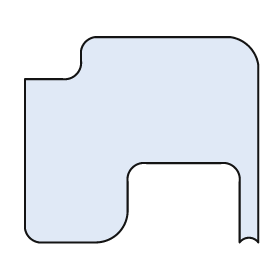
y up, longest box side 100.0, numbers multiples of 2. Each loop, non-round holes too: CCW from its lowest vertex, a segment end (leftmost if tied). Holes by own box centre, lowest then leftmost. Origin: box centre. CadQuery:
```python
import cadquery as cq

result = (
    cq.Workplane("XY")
    .moveTo(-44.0, -44.0)
    .lineTo(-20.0, -44.0)
    .threePointArc((-10.0, -40.0), (-6.0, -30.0))
    .lineTo(-6.0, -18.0)
    .threePointArc((-4.0, -12.0), (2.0, -10.0))
    .lineTo(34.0, -10.0)
    .threePointArc((40.0, -12.0), (42.0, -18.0))
    .lineTo(42.0, -44.0)
    .threePointArc((46.0, -42.0), (50.0, -44.0))
    .lineTo(50.0, 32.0)
    .threePointArc((46.0, 40.0), (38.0, 44.0))
    .lineTo(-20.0, 44.0)
    .threePointArc((-24.0, 42.0), (-26.0, 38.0))
    .lineTo(-26.0, 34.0)
    .threePointArc((-28.0, 28.0), (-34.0, 26.0))
    .lineTo(-50.0, 26.0)
    .lineTo(-50.0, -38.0)
    .threePointArc((-48.0, -42.0), (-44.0, -44.0))
    .close()
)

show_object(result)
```